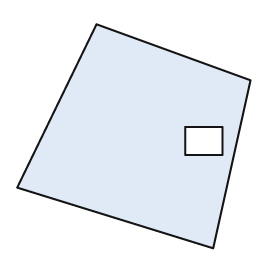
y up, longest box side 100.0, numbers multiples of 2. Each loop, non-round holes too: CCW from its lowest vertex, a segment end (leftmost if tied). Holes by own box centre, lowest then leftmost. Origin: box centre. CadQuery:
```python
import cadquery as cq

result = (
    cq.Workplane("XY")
    .moveTo(34.0, -48.0)
    .lineTo(50.0, 24.0)
    .lineTo(-16.0, 48.0)
    .lineTo(-50.0, -22.0)
    .close()
    .moveTo(22.0, -8.0)
    .lineTo(38.0, -8.0)
    .lineTo(38.0, 4.0)
    .lineTo(22.0, 4.0)
    .close()
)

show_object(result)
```